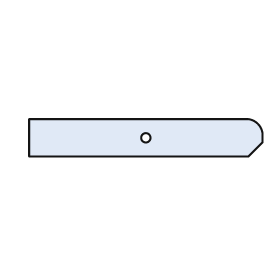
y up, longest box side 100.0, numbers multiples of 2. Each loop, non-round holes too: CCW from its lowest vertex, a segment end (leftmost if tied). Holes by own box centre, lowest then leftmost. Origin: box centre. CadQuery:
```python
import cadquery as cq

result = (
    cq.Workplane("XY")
    .moveTo(-50.0, -8.0)
    .lineTo(44.0, -8.0)
    .lineTo(50.0, -2.0)
    .lineTo(50.0, 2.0)
    .threePointArc((48.0, 6.0), (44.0, 8.0))
    .lineTo(-50.0, 8.0)
    .close()
    .moveTo(0.0, 0.0)
    .circle(2.0)
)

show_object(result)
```